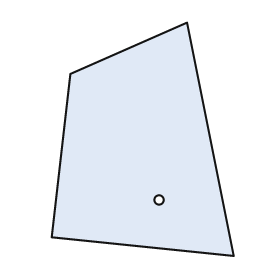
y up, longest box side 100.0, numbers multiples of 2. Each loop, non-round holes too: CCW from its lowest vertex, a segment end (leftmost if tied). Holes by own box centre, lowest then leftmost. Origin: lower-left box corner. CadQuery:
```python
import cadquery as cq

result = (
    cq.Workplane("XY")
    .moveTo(78.0, 0.0)
    .lineTo(58.0, 100.0)
    .lineTo(8.0, 78.0)
    .lineTo(0.0, 8.0)
    .close()
    .moveTo(46.0, 24.0)
    .circle(2.0)
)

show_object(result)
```